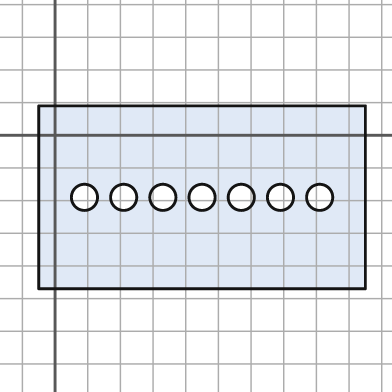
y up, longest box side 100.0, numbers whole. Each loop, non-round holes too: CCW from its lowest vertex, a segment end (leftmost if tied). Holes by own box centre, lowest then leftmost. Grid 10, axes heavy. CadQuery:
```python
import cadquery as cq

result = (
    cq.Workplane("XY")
    .moveTo(-5.0, -47.0)
    .lineTo(95.0, -47.0)
    .lineTo(95.0, 9.0)
    .lineTo(-5.0, 9.0)
    .close()
    .moveTo(9.0, -19.0)
    .circle(4.0)
    .moveTo(21.0, -19.0)
    .circle(4.0)
    .moveTo(33.0, -19.0)
    .circle(4.0)
    .moveTo(45.0, -19.0)
    .circle(4.0)
    .moveTo(57.0, -19.0)
    .circle(4.0)
    .moveTo(69.0, -19.0)
    .circle(4.0)
    .moveTo(81.0, -19.0)
    .circle(4.0)
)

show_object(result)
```